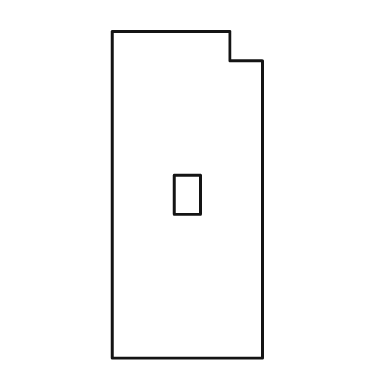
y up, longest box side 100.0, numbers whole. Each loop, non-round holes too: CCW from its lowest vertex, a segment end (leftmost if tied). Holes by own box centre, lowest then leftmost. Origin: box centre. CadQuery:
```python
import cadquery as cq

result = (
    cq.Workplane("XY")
    .moveTo(-23.0, -50.0)
    .lineTo(23.0, -50.0)
    .lineTo(23.0, 41.0)
    .lineTo(13.0, 41.0)
    .lineTo(13.0, 50.0)
    .lineTo(-23.0, 50.0)
    .close()
    .moveTo(-4.0, -6.0)
    .lineTo(4.0, -6.0)
    .lineTo(4.0, 6.0)
    .lineTo(-4.0, 6.0)
    .close()
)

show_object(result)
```